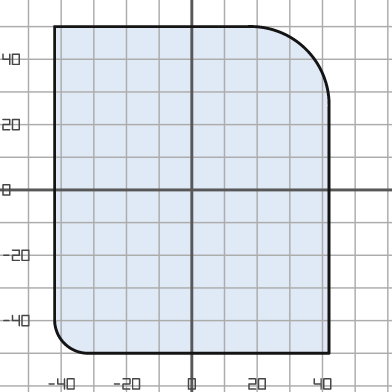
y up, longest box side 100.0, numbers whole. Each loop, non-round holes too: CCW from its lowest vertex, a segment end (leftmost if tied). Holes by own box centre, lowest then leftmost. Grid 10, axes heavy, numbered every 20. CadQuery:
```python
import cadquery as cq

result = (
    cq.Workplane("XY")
    .moveTo(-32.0, -50.0)
    .lineTo(42.0, -50.0)
    .lineTo(42.0, 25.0)
    .threePointArc((35.0, 43.0), (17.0, 50.0))
    .lineTo(-42.0, 50.0)
    .lineTo(-42.0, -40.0)
    .threePointArc((-39.0, -47.0), (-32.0, -50.0))
    .close()
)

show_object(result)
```